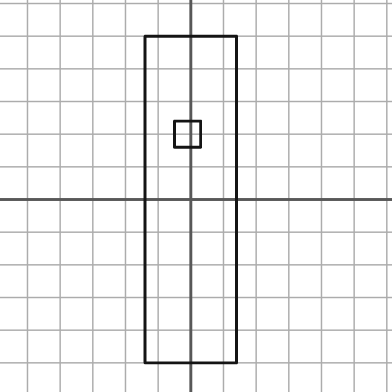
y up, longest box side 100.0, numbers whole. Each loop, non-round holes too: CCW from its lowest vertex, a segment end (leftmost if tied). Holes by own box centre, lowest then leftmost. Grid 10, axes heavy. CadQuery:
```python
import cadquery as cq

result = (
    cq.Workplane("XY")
    .moveTo(-14.0, -50.0)
    .lineTo(14.0, -50.0)
    .lineTo(14.0, 50.0)
    .lineTo(-14.0, 50.0)
    .close()
    .moveTo(-5.0, 16.0)
    .lineTo(3.0, 16.0)
    .lineTo(3.0, 24.0)
    .lineTo(-5.0, 24.0)
    .close()
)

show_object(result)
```